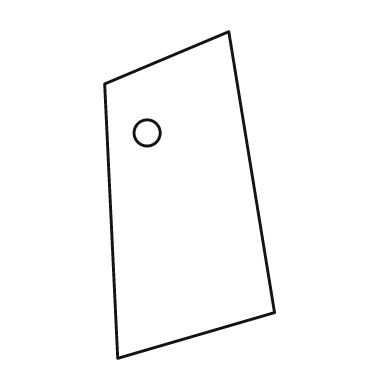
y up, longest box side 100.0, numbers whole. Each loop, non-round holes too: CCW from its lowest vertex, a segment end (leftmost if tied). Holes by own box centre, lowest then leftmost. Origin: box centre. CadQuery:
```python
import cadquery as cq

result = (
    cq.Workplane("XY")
    .moveTo(-22.0, -50.0)
    .lineTo(26.0, -36.0)
    .lineTo(12.0, 50.0)
    .lineTo(-26.0, 34.0)
    .close()
    .moveTo(-13.0, 19.0)
    .circle(4.0)
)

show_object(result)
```